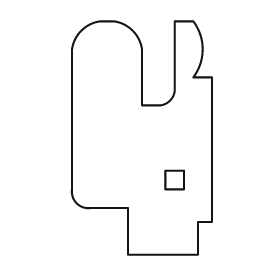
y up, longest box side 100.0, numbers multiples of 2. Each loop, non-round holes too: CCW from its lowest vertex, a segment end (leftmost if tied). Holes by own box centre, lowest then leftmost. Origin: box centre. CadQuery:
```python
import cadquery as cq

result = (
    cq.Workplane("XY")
    .moveTo(-6.0, -50.0)
    .lineTo(24.0, -50.0)
    .lineTo(24.0, -36.0)
    .lineTo(30.0, -36.0)
    .lineTo(30.0, 26.0)
    .lineTo(22.0, 26.0)
    .threePointArc((26.0, 38.0), (22.0, 50.0))
    .lineTo(14.0, 50.0)
    .lineTo(14.0, 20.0)
    .threePointArc((12.0, 16.0), (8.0, 14.0))
    .lineTo(0.0, 14.0)
    .lineTo(0.0, 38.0)
    .threePointArc((-4.0, 46.0), (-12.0, 50.0))
    .lineTo(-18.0, 50.0)
    .threePointArc((-26.0, 46.0), (-30.0, 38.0))
    .lineTo(-30.0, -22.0)
    .threePointArc((-28.0, -28.0), (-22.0, -30.0))
    .lineTo(-6.0, -30.0)
    .close()
    .moveTo(10.0, -22.0)
    .lineTo(18.0, -22.0)
    .lineTo(18.0, -14.0)
    .lineTo(10.0, -14.0)
    .close()
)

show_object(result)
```